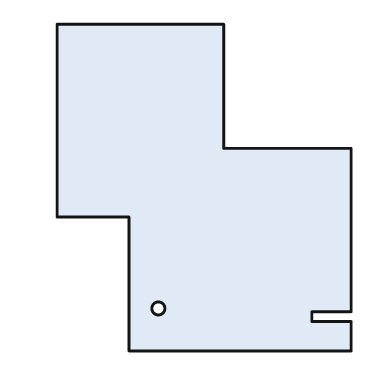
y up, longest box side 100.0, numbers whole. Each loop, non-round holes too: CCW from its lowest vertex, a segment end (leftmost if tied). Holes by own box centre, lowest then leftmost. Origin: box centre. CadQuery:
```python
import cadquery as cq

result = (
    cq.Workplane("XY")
    .moveTo(-23.0, -50.0)
    .lineTo(45.0, -50.0)
    .lineTo(45.0, -41.0)
    .lineTo(33.0, -41.0)
    .lineTo(33.0, -38.0)
    .lineTo(45.0, -38.0)
    .lineTo(45.0, 12.0)
    .lineTo(6.0, 12.0)
    .lineTo(6.0, 50.0)
    .lineTo(-45.0, 50.0)
    .lineTo(-45.0, -9.0)
    .lineTo(-23.0, -9.0)
    .close()
    .moveTo(-14.0, -37.0)
    .circle(2.0)
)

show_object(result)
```